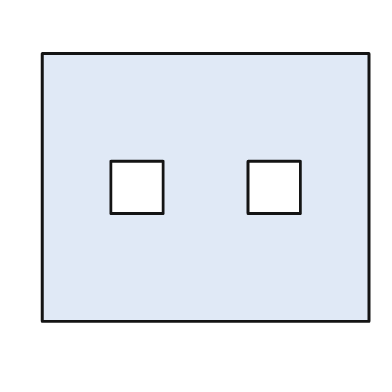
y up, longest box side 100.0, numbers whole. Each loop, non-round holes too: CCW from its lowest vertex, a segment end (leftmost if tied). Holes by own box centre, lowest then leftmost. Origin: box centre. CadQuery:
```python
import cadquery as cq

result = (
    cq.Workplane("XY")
    .moveTo(-50.0, -41.0)
    .lineTo(50.0, -41.0)
    .lineTo(50.0, 41.0)
    .lineTo(-50.0, 41.0)
    .close()
    .moveTo(-29.0, -8.0)
    .lineTo(-13.0, -8.0)
    .lineTo(-13.0, 8.0)
    .lineTo(-29.0, 8.0)
    .close()
    .moveTo(13.0, -8.0)
    .lineTo(29.0, -8.0)
    .lineTo(29.0, 8.0)
    .lineTo(13.0, 8.0)
    .close()
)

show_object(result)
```